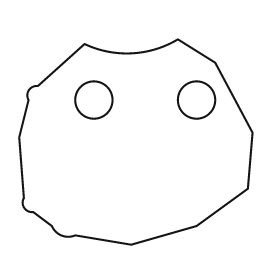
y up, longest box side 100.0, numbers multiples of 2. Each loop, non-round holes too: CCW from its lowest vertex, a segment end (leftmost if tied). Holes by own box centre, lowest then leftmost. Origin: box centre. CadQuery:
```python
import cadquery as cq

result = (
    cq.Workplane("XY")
    .moveTo(-2.0, -44.0)
    .lineTo(26.0, -36.0)
    .lineTo(48.0, -20.0)
    .lineTo(50.0, 4.0)
    .lineTo(34.0, 34.0)
    .lineTo(18.0, 44.0)
    .threePointArc((-2.0, 38.0), (-22.0, 42.0))
    .lineTo(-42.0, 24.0)
    .threePointArc((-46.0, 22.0), (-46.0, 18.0))
    .lineTo(-50.0, 2.0)
    .lineTo(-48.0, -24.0)
    .threePointArc((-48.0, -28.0), (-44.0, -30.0))
    .lineTo(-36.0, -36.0)
    .threePointArc((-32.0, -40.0), (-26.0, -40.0))
    .close()
    .moveTo(-18.0, 18.0)
    .circle(8.0)
    .moveTo(26.0, 18.0)
    .circle(8.0)
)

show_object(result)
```